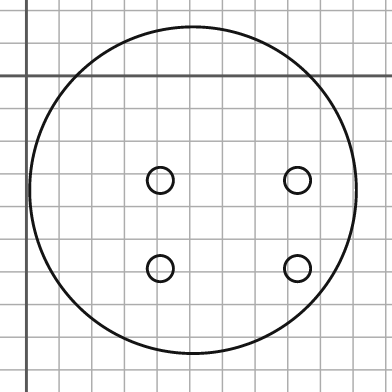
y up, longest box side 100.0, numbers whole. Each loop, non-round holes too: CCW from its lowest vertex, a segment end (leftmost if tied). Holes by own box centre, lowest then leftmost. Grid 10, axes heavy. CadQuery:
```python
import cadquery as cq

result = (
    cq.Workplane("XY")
    .moveTo(51.0, -35.0)
    .circle(50.0)
    .moveTo(41.0, -59.0)
    .circle(4.0)
    .moveTo(83.0, -59.0)
    .circle(4.0)
    .moveTo(41.0, -32.0)
    .circle(4.0)
    .moveTo(83.0, -32.0)
    .circle(4.0)
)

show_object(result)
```